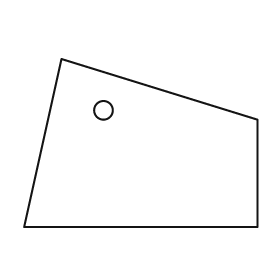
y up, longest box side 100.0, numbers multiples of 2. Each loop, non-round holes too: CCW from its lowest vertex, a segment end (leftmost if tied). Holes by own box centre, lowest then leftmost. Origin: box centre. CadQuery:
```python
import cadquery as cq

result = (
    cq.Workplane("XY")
    .moveTo(-50.0, -36.0)
    .lineTo(50.0, -36.0)
    .lineTo(50.0, 10.0)
    .lineTo(-34.0, 36.0)
    .close()
    .moveTo(-16.0, 14.0)
    .circle(4.0)
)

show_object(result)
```